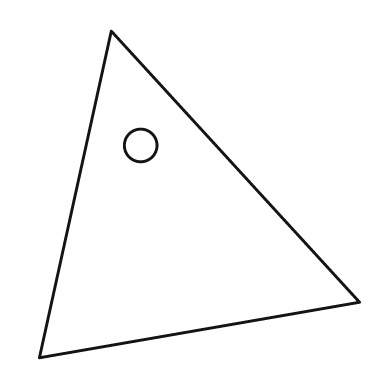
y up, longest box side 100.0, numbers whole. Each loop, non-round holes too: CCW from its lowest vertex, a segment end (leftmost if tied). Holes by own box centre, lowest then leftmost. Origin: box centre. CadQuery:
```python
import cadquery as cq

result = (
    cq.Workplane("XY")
    .moveTo(-49.0, -50.0)
    .lineTo(49.0, -33.0)
    .lineTo(-27.0, 50.0)
    .close()
    .moveTo(-18.0, 15.0)
    .circle(5.0)
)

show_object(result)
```